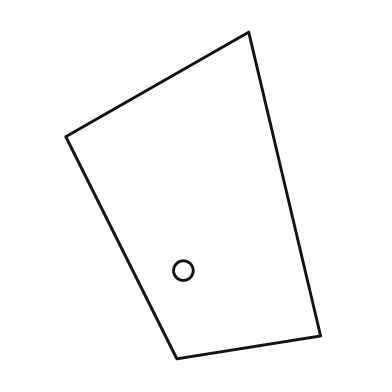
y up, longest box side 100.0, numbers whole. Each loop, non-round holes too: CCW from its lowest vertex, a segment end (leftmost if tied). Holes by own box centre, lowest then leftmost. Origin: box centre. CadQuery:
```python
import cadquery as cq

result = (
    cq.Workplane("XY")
    .moveTo(-5.0, -50.0)
    .lineTo(39.0, -43.0)
    .lineTo(17.0, 50.0)
    .lineTo(-39.0, 18.0)
    .close()
    .moveTo(-3.0, -23.0)
    .circle(3.0)
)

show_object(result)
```